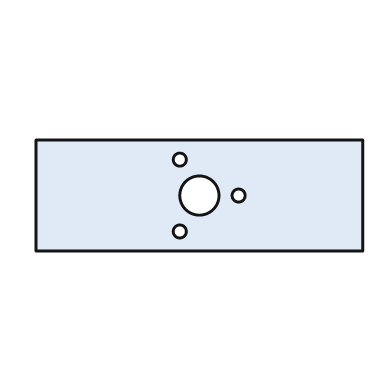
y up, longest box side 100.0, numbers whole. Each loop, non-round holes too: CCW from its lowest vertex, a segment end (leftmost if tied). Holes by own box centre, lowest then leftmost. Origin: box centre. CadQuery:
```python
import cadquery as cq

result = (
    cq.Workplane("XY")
    .moveTo(-50.0, -17.0)
    .lineTo(50.0, -17.0)
    .lineTo(50.0, 17.0)
    .lineTo(-50.0, 17.0)
    .close()
    .moveTo(-6.0, -11.0)
    .circle(2.0)
    .moveTo(0.0, 0.0)
    .circle(6.0)
    .moveTo(12.0, 0.0)
    .circle(2.0)
    .moveTo(-6.0, 11.0)
    .circle(2.0)
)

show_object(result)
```